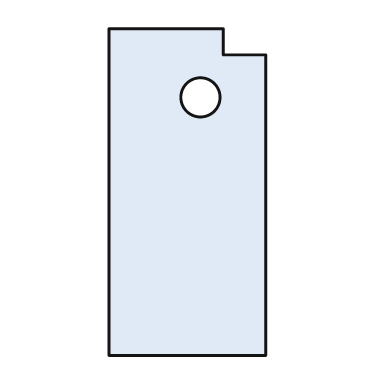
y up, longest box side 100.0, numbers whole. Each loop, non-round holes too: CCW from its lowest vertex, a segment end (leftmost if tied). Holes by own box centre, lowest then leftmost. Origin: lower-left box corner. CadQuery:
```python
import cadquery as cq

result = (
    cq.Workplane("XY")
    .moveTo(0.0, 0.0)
    .lineTo(48.0, 0.0)
    .lineTo(48.0, 92.0)
    .lineTo(35.0, 92.0)
    .lineTo(35.0, 100.0)
    .lineTo(0.0, 100.0)
    .close()
    .moveTo(28.0, 79.0)
    .circle(6.0)
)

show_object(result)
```